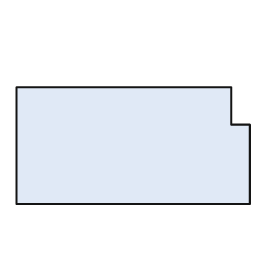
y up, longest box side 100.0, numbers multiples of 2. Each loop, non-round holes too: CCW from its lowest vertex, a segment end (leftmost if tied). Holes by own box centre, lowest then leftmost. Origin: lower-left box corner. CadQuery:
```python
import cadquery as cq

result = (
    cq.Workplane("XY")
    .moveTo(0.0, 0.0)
    .lineTo(100.0, 0.0)
    .lineTo(100.0, 34.0)
    .lineTo(92.0, 34.0)
    .lineTo(92.0, 50.0)
    .lineTo(0.0, 50.0)
    .close()
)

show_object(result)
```